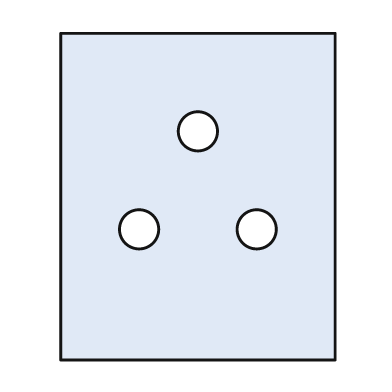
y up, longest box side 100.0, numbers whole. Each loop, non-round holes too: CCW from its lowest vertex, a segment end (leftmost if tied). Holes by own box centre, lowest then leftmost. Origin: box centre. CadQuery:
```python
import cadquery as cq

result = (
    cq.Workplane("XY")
    .moveTo(-42.0, -50.0)
    .lineTo(42.0, -50.0)
    .lineTo(42.0, 50.0)
    .lineTo(-42.0, 50.0)
    .close()
    .moveTo(-18.0, -10.0)
    .circle(6.0)
    .moveTo(18.0, -10.0)
    .circle(6.0)
    .moveTo(0.0, 20.0)
    .circle(6.0)
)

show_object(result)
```